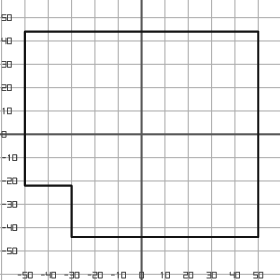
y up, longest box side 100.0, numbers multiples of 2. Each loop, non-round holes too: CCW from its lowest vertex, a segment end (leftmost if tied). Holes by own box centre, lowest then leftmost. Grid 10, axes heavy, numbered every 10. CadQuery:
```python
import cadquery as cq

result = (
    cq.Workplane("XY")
    .moveTo(-30.0, -44.0)
    .lineTo(50.0, -44.0)
    .lineTo(50.0, 44.0)
    .lineTo(-50.0, 44.0)
    .lineTo(-50.0, -22.0)
    .lineTo(-30.0, -22.0)
    .close()
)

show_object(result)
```